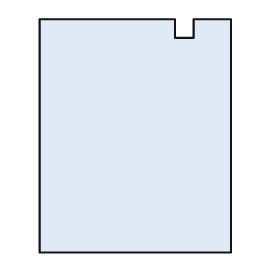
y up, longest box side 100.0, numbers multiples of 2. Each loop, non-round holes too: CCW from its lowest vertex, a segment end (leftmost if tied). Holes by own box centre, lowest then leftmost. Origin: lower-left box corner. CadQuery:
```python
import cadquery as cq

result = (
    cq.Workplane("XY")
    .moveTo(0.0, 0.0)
    .lineTo(82.0, 0.0)
    .lineTo(82.0, 100.0)
    .lineTo(66.0, 100.0)
    .lineTo(66.0, 92.0)
    .lineTo(58.0, 92.0)
    .lineTo(58.0, 100.0)
    .lineTo(0.0, 100.0)
    .close()
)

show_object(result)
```